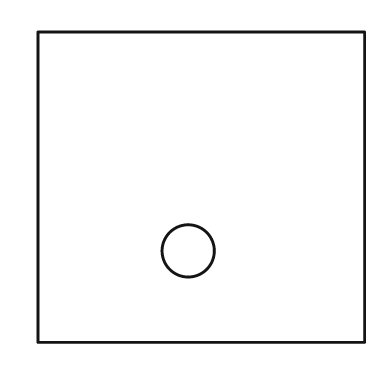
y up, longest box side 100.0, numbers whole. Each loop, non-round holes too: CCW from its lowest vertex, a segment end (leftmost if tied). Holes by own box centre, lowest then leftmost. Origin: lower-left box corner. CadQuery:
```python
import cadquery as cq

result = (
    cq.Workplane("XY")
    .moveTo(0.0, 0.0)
    .lineTo(100.0, 0.0)
    .lineTo(100.0, 95.0)
    .lineTo(0.0, 95.0)
    .close()
    .moveTo(46.0, 28.0)
    .circle(8.0)
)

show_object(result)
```